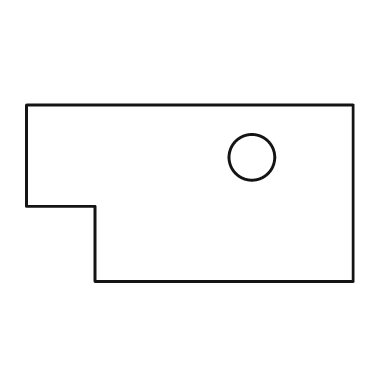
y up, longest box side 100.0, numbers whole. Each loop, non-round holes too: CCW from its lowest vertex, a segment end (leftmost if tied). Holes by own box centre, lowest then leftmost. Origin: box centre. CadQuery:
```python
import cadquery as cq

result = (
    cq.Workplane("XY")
    .moveTo(-29.0, -27.0)
    .lineTo(50.0, -27.0)
    .lineTo(50.0, 27.0)
    .lineTo(-50.0, 27.0)
    .lineTo(-50.0, -4.0)
    .lineTo(-29.0, -4.0)
    .close()
    .moveTo(19.0, 11.0)
    .circle(7.0)
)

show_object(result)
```